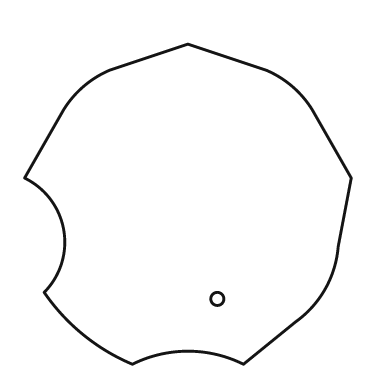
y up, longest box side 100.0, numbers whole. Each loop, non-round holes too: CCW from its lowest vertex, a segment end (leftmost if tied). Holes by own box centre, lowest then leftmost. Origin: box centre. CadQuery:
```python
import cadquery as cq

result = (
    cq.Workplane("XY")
    .moveTo(-17.0, -49.0)
    .threePointArc((0.0, -45.0), (17.0, -49.0))
    .lineTo(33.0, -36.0)
    .threePointArc((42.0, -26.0), (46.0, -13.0))
    .lineTo(50.0, 8.0)
    .lineTo(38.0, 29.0)
    .threePointArc((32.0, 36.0), (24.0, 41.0))
    .lineTo(0.0, 49.0)
    .lineTo(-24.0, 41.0)
    .threePointArc((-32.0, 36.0), (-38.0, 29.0))
    .lineTo(-50.0, 8.0)
    .threePointArc((-38.0, -8.0), (-44.0, -27.0))
    .threePointArc((-32.0, -40.0), (-17.0, -49.0))
    .close()
    .moveTo(9.0, -29.0)
    .circle(2.0)
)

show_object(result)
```